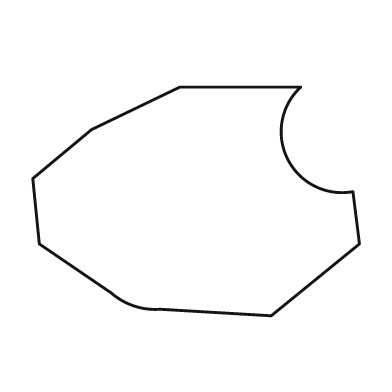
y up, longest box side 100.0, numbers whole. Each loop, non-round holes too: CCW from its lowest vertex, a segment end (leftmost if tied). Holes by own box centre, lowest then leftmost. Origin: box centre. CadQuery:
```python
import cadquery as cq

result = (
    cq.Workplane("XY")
    .moveTo(23.0, -35.0)
    .lineTo(50.0, -13.0)
    .lineTo(48.0, 3.0)
    .threePointArc((28.0, 13.0), (32.0, 35.0))
    .lineTo(-5.0, 35.0)
    .lineTo(-32.0, 22.0)
    .lineTo(-50.0, 7.0)
    .lineTo(-48.0, -13.0)
    .lineTo(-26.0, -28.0)
    .threePointArc((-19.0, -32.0), (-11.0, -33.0))
    .close()
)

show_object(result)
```